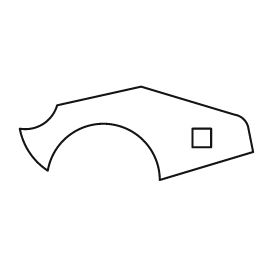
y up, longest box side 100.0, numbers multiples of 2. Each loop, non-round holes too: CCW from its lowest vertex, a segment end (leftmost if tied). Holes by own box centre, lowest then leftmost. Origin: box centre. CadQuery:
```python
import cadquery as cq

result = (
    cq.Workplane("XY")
    .moveTo(10.0, -20.0)
    .lineTo(50.0, -8.0)
    .lineTo(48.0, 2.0)
    .threePointArc((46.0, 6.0), (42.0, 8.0))
    .lineTo(2.0, 20.0)
    .lineTo(-34.0, 12.0)
    .threePointArc((-40.0, 4.0), (-50.0, 2.0))
    .threePointArc((-46.0, -8.0), (-38.0, -16.0))
    .threePointArc((-12.0, 4.0), (10.0, -20.0))
    .close()
    .moveTo(24.0, -6.0)
    .lineTo(32.0, -6.0)
    .lineTo(32.0, 2.0)
    .lineTo(24.0, 2.0)
    .close()
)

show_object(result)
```